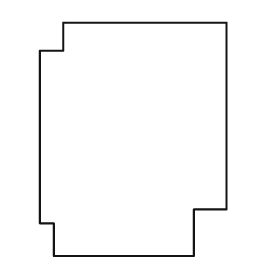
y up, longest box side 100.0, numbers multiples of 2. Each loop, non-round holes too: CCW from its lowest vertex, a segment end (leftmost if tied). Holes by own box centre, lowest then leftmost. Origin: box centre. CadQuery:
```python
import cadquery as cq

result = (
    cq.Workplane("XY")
    .moveTo(-34.0, -50.0)
    .lineTo(26.0, -50.0)
    .lineTo(26.0, -30.0)
    .lineTo(40.0, -30.0)
    .lineTo(40.0, 50.0)
    .lineTo(-30.0, 50.0)
    .lineTo(-30.0, 38.0)
    .lineTo(-40.0, 38.0)
    .lineTo(-40.0, -36.0)
    .lineTo(-34.0, -36.0)
    .close()
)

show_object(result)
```